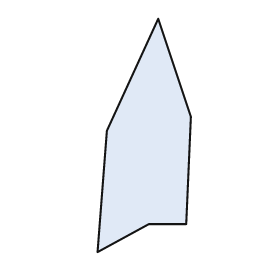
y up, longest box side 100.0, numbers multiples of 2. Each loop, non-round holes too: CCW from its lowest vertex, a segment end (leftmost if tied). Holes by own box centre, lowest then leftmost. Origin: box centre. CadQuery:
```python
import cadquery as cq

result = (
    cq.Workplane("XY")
    .moveTo(-20.0, -50.0)
    .lineTo(2.0, -38.0)
    .lineTo(18.0, -38.0)
    .lineTo(20.0, 8.0)
    .lineTo(6.0, 50.0)
    .lineTo(-16.0, 2.0)
    .close()
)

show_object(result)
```